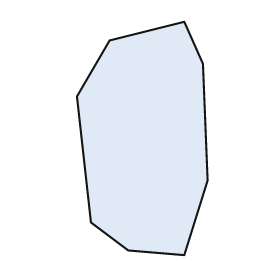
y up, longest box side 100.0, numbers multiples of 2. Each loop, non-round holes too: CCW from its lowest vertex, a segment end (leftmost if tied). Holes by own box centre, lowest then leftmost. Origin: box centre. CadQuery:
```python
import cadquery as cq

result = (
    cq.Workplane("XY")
    .moveTo(18.0, -50.0)
    .lineTo(28.0, -18.0)
    .lineTo(26.0, 32.0)
    .lineTo(18.0, 50.0)
    .lineTo(-14.0, 42.0)
    .lineTo(-28.0, 18.0)
    .lineTo(-22.0, -36.0)
    .lineTo(-6.0, -48.0)
    .close()
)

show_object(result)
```